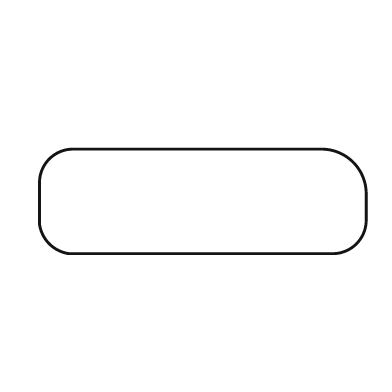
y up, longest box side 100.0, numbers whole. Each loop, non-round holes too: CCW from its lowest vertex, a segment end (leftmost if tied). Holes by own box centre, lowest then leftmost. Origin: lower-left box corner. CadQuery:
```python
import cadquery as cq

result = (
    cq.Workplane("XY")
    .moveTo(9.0, 0.0)
    .lineTo(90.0, 0.0)
    .threePointArc((97.0, 3.0), (100.0, 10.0))
    .lineTo(100.0, 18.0)
    .threePointArc((96.0, 28.0), (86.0, 32.0))
    .lineTo(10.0, 32.0)
    .threePointArc((3.0, 29.0), (0.0, 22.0))
    .lineTo(0.0, 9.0)
    .threePointArc((3.0, 3.0), (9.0, 0.0))
    .close()
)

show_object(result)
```